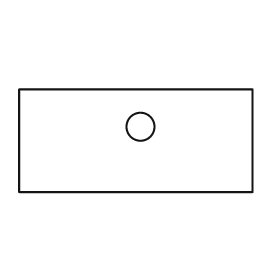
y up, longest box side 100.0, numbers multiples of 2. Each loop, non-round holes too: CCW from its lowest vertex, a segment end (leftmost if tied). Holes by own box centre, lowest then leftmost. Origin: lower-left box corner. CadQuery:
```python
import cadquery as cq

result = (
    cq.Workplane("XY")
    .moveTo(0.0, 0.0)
    .lineTo(100.0, 0.0)
    .lineTo(100.0, 44.0)
    .lineTo(0.0, 44.0)
    .close()
    .moveTo(52.0, 28.0)
    .circle(6.0)
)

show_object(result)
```